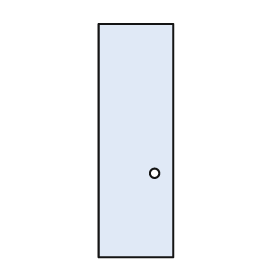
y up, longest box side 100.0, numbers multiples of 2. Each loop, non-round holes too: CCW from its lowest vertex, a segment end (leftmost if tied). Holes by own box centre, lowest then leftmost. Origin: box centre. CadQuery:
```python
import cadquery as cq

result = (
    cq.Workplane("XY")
    .moveTo(-16.0, -50.0)
    .lineTo(16.0, -50.0)
    .lineTo(16.0, 50.0)
    .lineTo(-16.0, 50.0)
    .close()
    .moveTo(8.0, -14.0)
    .circle(2.0)
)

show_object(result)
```